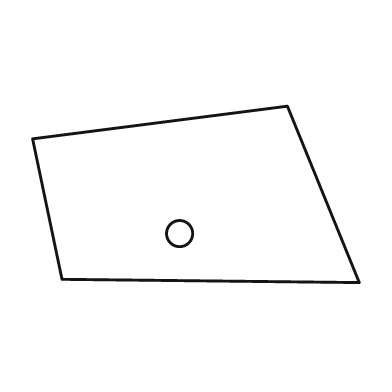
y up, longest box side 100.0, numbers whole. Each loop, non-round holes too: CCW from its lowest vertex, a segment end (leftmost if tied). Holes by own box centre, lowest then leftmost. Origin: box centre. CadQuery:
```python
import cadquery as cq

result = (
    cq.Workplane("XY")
    .moveTo(50.0, -27.0)
    .lineTo(28.0, 27.0)
    .lineTo(-50.0, 17.0)
    .lineTo(-41.0, -26.0)
    .close()
    .moveTo(-5.0, -12.0)
    .circle(4.0)
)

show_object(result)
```